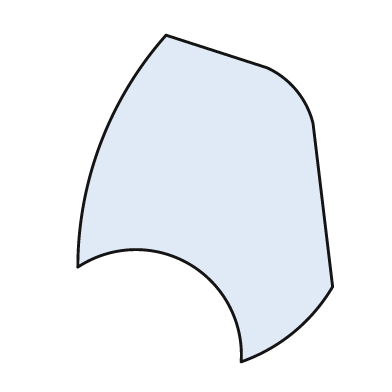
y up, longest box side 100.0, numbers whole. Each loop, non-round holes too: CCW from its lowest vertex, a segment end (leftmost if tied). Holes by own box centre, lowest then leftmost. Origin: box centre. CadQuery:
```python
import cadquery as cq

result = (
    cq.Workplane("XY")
    .moveTo(11.0, -50.0)
    .threePointArc((27.0, -41.0), (39.0, -27.0))
    .lineTo(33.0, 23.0)
    .threePointArc((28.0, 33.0), (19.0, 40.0))
    .lineTo(-12.0, 50.0)
    .threePointArc((-32.0, 17.0), (-39.0, -21.0))
    .threePointArc((-5.0, -20.0), (11.0, -50.0))
    .close()
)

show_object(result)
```